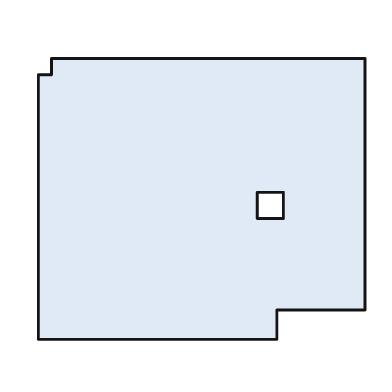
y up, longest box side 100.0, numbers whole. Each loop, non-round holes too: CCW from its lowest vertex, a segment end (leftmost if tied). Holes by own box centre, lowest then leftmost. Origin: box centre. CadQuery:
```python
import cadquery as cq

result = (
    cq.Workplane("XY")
    .moveTo(-50.0, -43.0)
    .lineTo(23.0, -43.0)
    .lineTo(23.0, -34.0)
    .lineTo(50.0, -34.0)
    .lineTo(50.0, 43.0)
    .lineTo(-46.0, 43.0)
    .lineTo(-46.0, 38.0)
    .lineTo(-50.0, 38.0)
    .close()
    .moveTo(17.0, -6.0)
    .lineTo(25.0, -6.0)
    .lineTo(25.0, 2.0)
    .lineTo(17.0, 2.0)
    .close()
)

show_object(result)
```